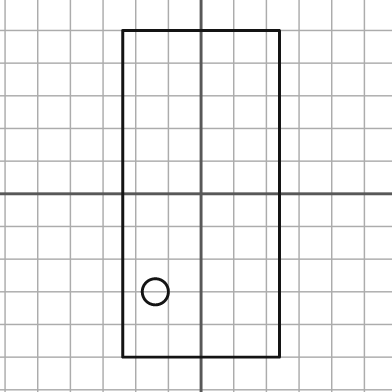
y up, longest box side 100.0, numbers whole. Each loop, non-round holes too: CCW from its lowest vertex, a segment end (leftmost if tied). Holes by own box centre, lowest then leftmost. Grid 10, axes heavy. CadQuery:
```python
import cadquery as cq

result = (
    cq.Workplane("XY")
    .moveTo(-24.0, -50.0)
    .lineTo(24.0, -50.0)
    .lineTo(24.0, 50.0)
    .lineTo(-24.0, 50.0)
    .close()
    .moveTo(-14.0, -30.0)
    .circle(4.0)
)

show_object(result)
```